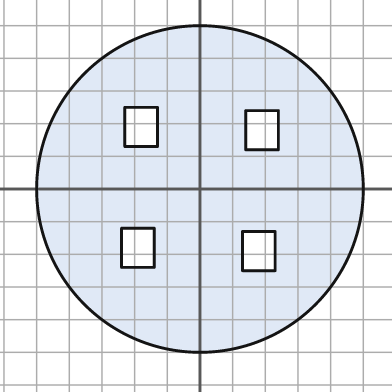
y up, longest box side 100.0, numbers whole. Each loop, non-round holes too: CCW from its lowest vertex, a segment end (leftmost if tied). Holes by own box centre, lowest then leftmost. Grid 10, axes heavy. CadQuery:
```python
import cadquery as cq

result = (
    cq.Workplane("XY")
    .moveTo(0.0, 0.0)
    .circle(50.0)
    .moveTo(13.0, -25.0)
    .lineTo(23.0, -25.0)
    .lineTo(23.0, -13.0)
    .lineTo(13.0, -13.0)
    .close()
    .moveTo(-24.0, -24.0)
    .lineTo(-14.0, -24.0)
    .lineTo(-14.0, -12.0)
    .lineTo(-24.0, -12.0)
    .close()
    .moveTo(14.0, 12.0)
    .lineTo(24.0, 12.0)
    .lineTo(24.0, 24.0)
    .lineTo(14.0, 24.0)
    .close()
    .moveTo(-23.0, 13.0)
    .lineTo(-13.0, 13.0)
    .lineTo(-13.0, 25.0)
    .lineTo(-23.0, 25.0)
    .close()
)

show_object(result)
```